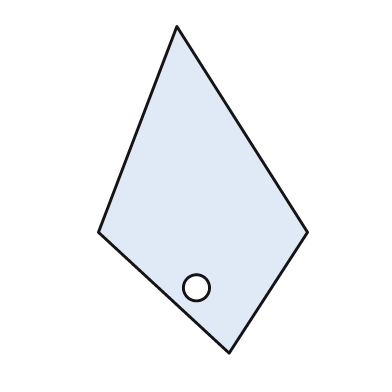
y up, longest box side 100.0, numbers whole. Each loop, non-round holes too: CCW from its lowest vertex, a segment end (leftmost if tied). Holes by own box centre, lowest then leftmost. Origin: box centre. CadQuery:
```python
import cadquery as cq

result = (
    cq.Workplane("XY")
    .moveTo(8.0, -50.0)
    .lineTo(32.0, -13.0)
    .lineTo(-8.0, 50.0)
    .lineTo(-32.0, -13.0)
    .close()
    .moveTo(-2.0, -30.0)
    .circle(4.0)
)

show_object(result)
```